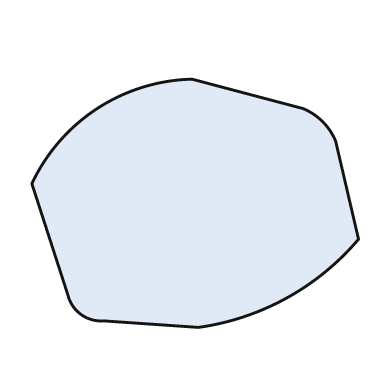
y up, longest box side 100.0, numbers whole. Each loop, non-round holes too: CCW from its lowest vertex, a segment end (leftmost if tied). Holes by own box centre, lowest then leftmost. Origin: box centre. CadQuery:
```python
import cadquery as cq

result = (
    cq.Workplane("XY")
    .moveTo(1.0, -38.0)
    .threePointArc((28.0, -29.0), (50.0, -11.0))
    .lineTo(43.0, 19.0)
    .threePointArc((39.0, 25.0), (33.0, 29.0))
    .lineTo(-1.0, 38.0)
    .threePointArc((-30.0, 29.0), (-50.0, 6.0))
    .lineTo(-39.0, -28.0)
    .threePointArc((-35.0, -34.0), (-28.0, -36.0))
    .close()
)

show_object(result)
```